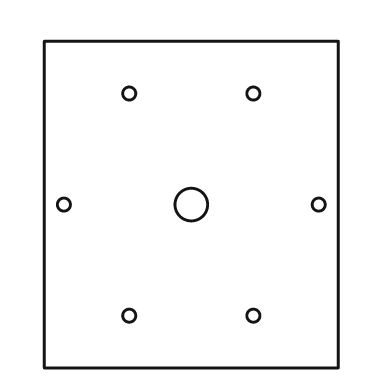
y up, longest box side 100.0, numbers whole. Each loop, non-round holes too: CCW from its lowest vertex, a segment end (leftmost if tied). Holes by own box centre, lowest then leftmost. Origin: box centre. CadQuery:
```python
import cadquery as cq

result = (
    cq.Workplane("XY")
    .moveTo(-45.0, -50.0)
    .lineTo(45.0, -50.0)
    .lineTo(45.0, 50.0)
    .lineTo(-45.0, 50.0)
    .close()
    .moveTo(-19.0, -34.0)
    .circle(2.0)
    .moveTo(19.0, -34.0)
    .circle(2.0)
    .moveTo(-39.0, 0.0)
    .circle(2.0)
    .moveTo(0.0, 0.0)
    .circle(5.0)
    .moveTo(39.0, 0.0)
    .circle(2.0)
    .moveTo(-19.0, 34.0)
    .circle(2.0)
    .moveTo(19.0, 34.0)
    .circle(2.0)
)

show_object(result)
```